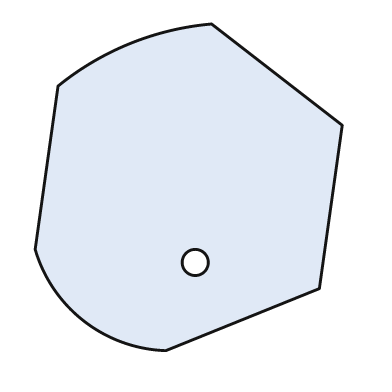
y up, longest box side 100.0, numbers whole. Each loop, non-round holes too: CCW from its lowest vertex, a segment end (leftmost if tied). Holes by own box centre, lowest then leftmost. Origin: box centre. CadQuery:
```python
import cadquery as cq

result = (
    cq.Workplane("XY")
    .moveTo(-7.0, -50.0)
    .lineTo(40.0, -31.0)
    .lineTo(47.0, 19.0)
    .lineTo(7.0, 50.0)
    .threePointArc((-18.0, 44.0), (-40.0, 31.0))
    .lineTo(-47.0, -19.0)
    .threePointArc((-32.0, -41.0), (-7.0, -50.0))
    .close()
    .moveTo(2.0, -23.0)
    .circle(4.0)
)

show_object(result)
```